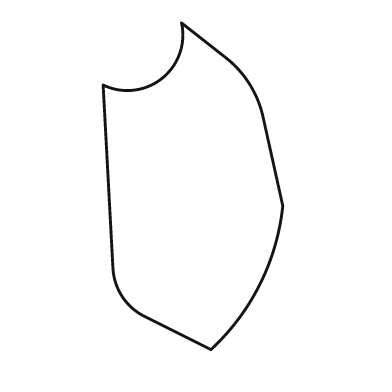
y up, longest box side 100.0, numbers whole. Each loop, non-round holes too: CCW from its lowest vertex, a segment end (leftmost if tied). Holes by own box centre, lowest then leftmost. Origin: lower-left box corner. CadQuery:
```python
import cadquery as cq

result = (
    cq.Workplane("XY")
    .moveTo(33.0, 0.0)
    .threePointArc((48.0, 20.0), (55.0, 44.0))
    .lineTo(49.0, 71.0)
    .threePointArc((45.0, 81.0), (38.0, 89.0))
    .lineTo(24.0, 100.0)
    .threePointArc((18.0, 83.0), (0.0, 81.0))
    .lineTo(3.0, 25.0)
    .threePointArc((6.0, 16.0), (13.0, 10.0))
    .close()
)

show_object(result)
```